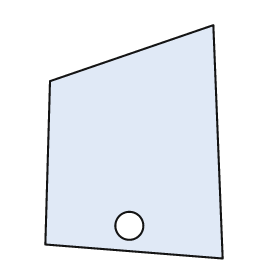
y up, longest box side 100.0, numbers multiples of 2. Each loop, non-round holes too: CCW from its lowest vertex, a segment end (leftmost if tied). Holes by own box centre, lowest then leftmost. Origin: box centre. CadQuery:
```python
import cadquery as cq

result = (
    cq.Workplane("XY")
    .moveTo(38.0, -50.0)
    .lineTo(34.0, 50.0)
    .lineTo(-36.0, 26.0)
    .lineTo(-38.0, -44.0)
    .close()
    .moveTo(-2.0, -36.0)
    .circle(6.0)
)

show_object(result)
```